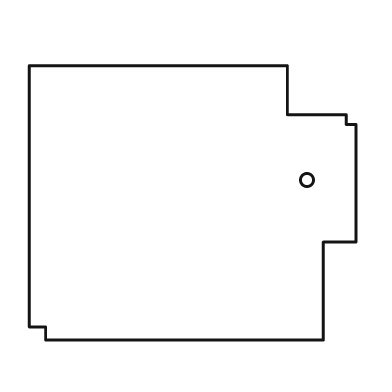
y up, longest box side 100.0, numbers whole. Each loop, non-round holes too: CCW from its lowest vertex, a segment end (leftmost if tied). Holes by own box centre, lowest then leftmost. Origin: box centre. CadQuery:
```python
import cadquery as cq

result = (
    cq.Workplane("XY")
    .moveTo(-45.0, -42.0)
    .lineTo(40.0, -42.0)
    .lineTo(40.0, -12.0)
    .lineTo(50.0, -12.0)
    .lineTo(50.0, 24.0)
    .lineTo(47.0, 24.0)
    .lineTo(47.0, 27.0)
    .lineTo(29.0, 27.0)
    .lineTo(29.0, 42.0)
    .lineTo(-50.0, 42.0)
    .lineTo(-50.0, -38.0)
    .lineTo(-45.0, -38.0)
    .close()
    .moveTo(35.0, 7.0)
    .circle(2.0)
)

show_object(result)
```